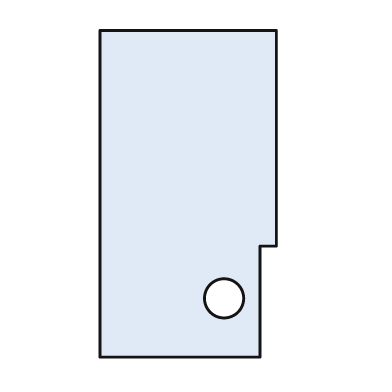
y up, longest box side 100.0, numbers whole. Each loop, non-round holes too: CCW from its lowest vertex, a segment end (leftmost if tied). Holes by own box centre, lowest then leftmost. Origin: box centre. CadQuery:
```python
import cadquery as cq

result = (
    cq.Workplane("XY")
    .moveTo(-27.0, -50.0)
    .lineTo(22.0, -50.0)
    .lineTo(22.0, -16.0)
    .lineTo(27.0, -16.0)
    .lineTo(27.0, 50.0)
    .lineTo(-27.0, 50.0)
    .close()
    .moveTo(11.0, -32.0)
    .circle(6.0)
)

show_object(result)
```